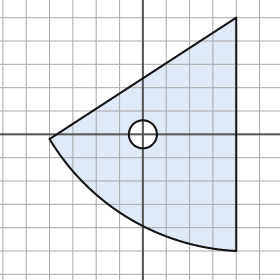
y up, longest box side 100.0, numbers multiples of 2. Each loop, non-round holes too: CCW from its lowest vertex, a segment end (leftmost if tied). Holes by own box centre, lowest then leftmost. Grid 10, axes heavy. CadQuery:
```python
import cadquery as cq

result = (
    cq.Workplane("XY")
    .moveTo(40.0, -50.0)
    .lineTo(40.0, 50.0)
    .lineTo(-40.0, -2.0)
    .threePointArc((-6.0, -36.0), (40.0, -50.0))
    .close()
    .moveTo(0.0, 0.0)
    .circle(6.0)
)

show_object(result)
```